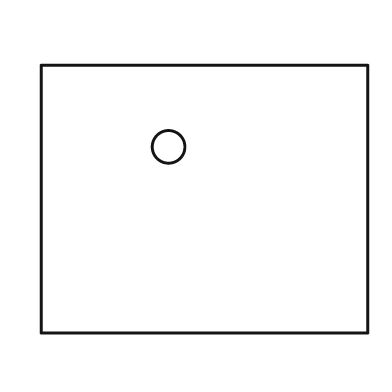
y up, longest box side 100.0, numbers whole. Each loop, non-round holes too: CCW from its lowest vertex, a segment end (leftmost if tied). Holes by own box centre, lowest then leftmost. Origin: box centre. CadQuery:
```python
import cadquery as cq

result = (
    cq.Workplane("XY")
    .moveTo(-50.0, -41.0)
    .lineTo(50.0, -41.0)
    .lineTo(50.0, 41.0)
    .lineTo(-50.0, 41.0)
    .close()
    .moveTo(-11.0, 16.0)
    .circle(5.0)
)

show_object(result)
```